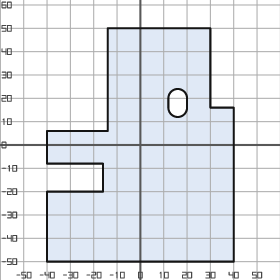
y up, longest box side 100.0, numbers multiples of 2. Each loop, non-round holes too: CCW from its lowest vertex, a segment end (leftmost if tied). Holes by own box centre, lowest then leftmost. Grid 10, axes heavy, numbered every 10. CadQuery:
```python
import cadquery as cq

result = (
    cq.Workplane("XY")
    .moveTo(-40.0, -50.0)
    .lineTo(40.0, -50.0)
    .lineTo(40.0, 16.0)
    .lineTo(30.0, 16.0)
    .lineTo(30.0, 50.0)
    .lineTo(-14.0, 50.0)
    .lineTo(-14.0, 6.0)
    .lineTo(-40.0, 6.0)
    .lineTo(-40.0, -8.0)
    .lineTo(-16.0, -8.0)
    .lineTo(-16.0, -20.0)
    .lineTo(-40.0, -20.0)
    .close()
    .moveTo(12.0, 16.0)
    .threePointArc((16.0, 12.0), (20.0, 16.0))
    .lineTo(20.0, 20.0)
    .threePointArc((16.0, 24.0), (12.0, 20.0))
    .close()
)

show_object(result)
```